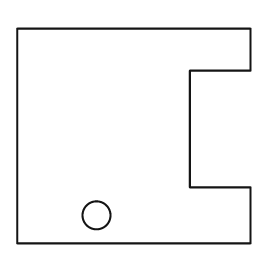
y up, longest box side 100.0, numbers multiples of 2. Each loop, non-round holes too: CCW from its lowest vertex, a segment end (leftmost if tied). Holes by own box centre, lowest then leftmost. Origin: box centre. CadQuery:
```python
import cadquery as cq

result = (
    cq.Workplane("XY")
    .moveTo(-50.0, -46.0)
    .lineTo(50.0, -46.0)
    .lineTo(50.0, -22.0)
    .lineTo(24.0, -22.0)
    .lineTo(24.0, 28.0)
    .lineTo(50.0, 28.0)
    .lineTo(50.0, 46.0)
    .lineTo(-50.0, 46.0)
    .close()
    .moveTo(-16.0, -34.0)
    .circle(6.0)
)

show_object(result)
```